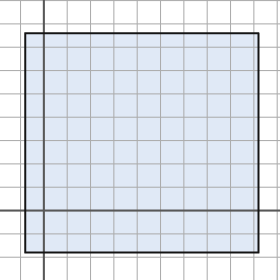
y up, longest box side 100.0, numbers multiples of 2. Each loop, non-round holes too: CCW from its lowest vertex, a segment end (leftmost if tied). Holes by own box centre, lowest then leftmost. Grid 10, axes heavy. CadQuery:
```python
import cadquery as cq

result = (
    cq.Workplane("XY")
    .moveTo(-8.0, -18.0)
    .lineTo(92.0, -18.0)
    .lineTo(92.0, 76.0)
    .lineTo(-8.0, 76.0)
    .close()
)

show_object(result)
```